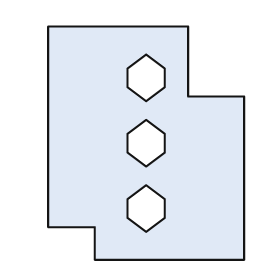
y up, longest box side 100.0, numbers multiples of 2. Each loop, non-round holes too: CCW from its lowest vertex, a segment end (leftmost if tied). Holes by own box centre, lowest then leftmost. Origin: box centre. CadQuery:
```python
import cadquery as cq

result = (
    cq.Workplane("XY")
    .moveTo(-22.0, -50.0)
    .lineTo(42.0, -50.0)
    .lineTo(42.0, 20.0)
    .lineTo(18.0, 20.0)
    .lineTo(18.0, 50.0)
    .lineTo(-42.0, 50.0)
    .lineTo(-42.0, -36.0)
    .lineTo(-22.0, -36.0)
    .close()
    .moveTo(0.0, -38.0)
    .lineTo(8.0, -32.0)
    .lineTo(8.0, -24.0)
    .lineTo(0.0, -18.0)
    .lineTo(-8.0, -24.0)
    .lineTo(-8.0, -32.0)
    .close()
    .moveTo(0.0, -10.0)
    .lineTo(8.0, -4.0)
    .lineTo(8.0, 4.0)
    .lineTo(0.0, 10.0)
    .lineTo(-8.0, 4.0)
    .lineTo(-8.0, -4.0)
    .close()
    .moveTo(0.0, 18.0)
    .lineTo(8.0, 24.0)
    .lineTo(8.0, 32.0)
    .lineTo(0.0, 38.0)
    .lineTo(-8.0, 32.0)
    .lineTo(-8.0, 24.0)
    .close()
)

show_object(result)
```